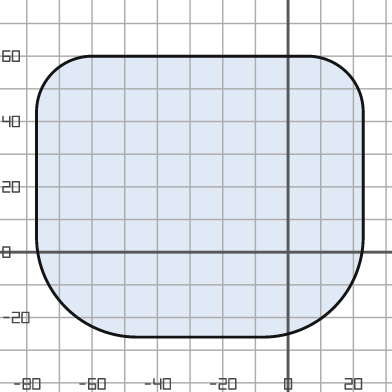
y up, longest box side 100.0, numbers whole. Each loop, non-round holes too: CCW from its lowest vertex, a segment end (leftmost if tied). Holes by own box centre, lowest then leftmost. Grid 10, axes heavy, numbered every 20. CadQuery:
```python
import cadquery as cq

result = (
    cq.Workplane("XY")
    .moveTo(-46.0, -26.0)
    .lineTo(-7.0, -26.0)
    .threePointArc((14.0, -17.0), (23.0, 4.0))
    .lineTo(23.0, 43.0)
    .threePointArc((18.0, 55.0), (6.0, 60.0))
    .lineTo(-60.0, 60.0)
    .threePointArc((-72.0, 55.0), (-77.0, 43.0))
    .lineTo(-77.0, 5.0)
    .threePointArc((-68.0, -17.0), (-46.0, -26.0))
    .close()
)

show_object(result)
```